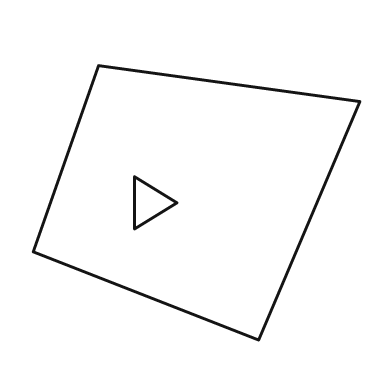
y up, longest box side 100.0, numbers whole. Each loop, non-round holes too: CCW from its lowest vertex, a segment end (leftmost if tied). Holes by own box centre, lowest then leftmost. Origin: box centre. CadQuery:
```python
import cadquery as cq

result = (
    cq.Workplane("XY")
    .moveTo(19.0, -42.0)
    .lineTo(50.0, 31.0)
    .lineTo(-30.0, 42.0)
    .lineTo(-50.0, -15.0)
    .close()
    .moveTo(-19.0, -8.0)
    .lineTo(-6.0, 0.0)
    .lineTo(-19.0, 8.0)
    .close()
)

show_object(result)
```